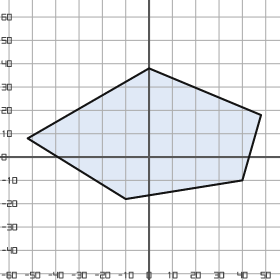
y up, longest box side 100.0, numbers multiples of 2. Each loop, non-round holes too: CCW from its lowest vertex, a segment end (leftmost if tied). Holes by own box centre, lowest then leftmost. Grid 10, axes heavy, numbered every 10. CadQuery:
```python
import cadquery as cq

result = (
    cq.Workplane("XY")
    .moveTo(-10.0, -18.0)
    .lineTo(40.0, -10.0)
    .lineTo(48.0, 18.0)
    .lineTo(0.0, 38.0)
    .lineTo(-52.0, 8.0)
    .close()
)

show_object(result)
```